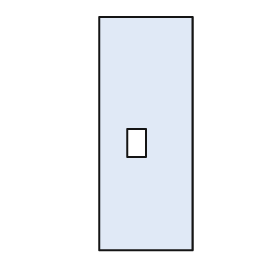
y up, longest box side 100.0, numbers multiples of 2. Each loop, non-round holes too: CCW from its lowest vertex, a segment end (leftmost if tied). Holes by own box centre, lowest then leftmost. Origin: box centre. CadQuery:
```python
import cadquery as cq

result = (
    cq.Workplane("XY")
    .moveTo(-20.0, -50.0)
    .lineTo(20.0, -50.0)
    .lineTo(20.0, 50.0)
    .lineTo(-20.0, 50.0)
    .close()
    .moveTo(-8.0, -10.0)
    .lineTo(0.0, -10.0)
    .lineTo(0.0, 2.0)
    .lineTo(-8.0, 2.0)
    .close()
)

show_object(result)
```